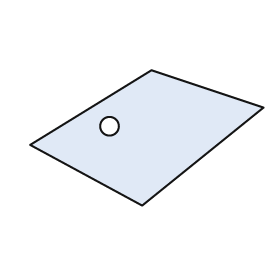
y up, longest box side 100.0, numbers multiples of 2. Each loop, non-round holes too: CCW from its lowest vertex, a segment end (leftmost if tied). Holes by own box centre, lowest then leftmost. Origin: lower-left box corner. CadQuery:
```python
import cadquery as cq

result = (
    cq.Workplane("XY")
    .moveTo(48.0, 0.0)
    .lineTo(100.0, 42.0)
    .lineTo(52.0, 58.0)
    .lineTo(0.0, 26.0)
    .close()
    .moveTo(34.0, 34.0)
    .circle(4.0)
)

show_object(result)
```